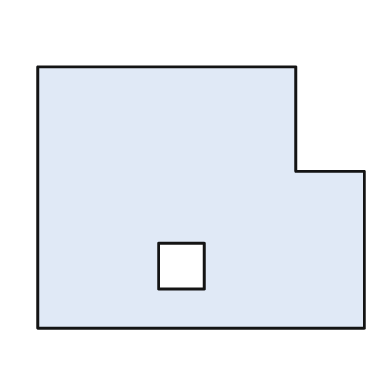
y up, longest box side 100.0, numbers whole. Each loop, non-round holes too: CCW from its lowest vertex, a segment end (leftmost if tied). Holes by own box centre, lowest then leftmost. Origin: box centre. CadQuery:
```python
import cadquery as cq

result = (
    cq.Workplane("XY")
    .moveTo(-50.0, -40.0)
    .lineTo(50.0, -40.0)
    .lineTo(50.0, 8.0)
    .lineTo(29.0, 8.0)
    .lineTo(29.0, 40.0)
    .lineTo(-50.0, 40.0)
    .close()
    .moveTo(-13.0, -28.0)
    .lineTo(1.0, -28.0)
    .lineTo(1.0, -14.0)
    .lineTo(-13.0, -14.0)
    .close()
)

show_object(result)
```